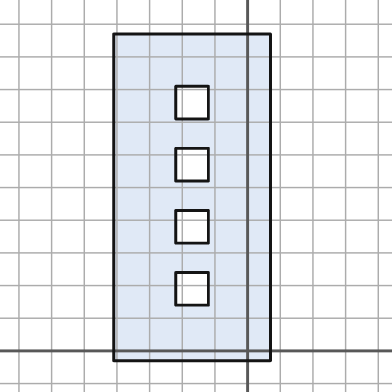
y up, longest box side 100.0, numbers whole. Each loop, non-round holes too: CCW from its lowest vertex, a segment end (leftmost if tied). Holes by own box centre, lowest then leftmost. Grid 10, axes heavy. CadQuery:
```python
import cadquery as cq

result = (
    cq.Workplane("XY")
    .moveTo(-41.0, -3.0)
    .lineTo(7.0, -3.0)
    .lineTo(7.0, 97.0)
    .lineTo(-41.0, 97.0)
    .close()
    .moveTo(-22.0, 14.0)
    .lineTo(-12.0, 14.0)
    .lineTo(-12.0, 24.0)
    .lineTo(-22.0, 24.0)
    .close()
    .moveTo(-22.0, 33.0)
    .lineTo(-12.0, 33.0)
    .lineTo(-12.0, 43.0)
    .lineTo(-22.0, 43.0)
    .close()
    .moveTo(-22.0, 52.0)
    .lineTo(-12.0, 52.0)
    .lineTo(-12.0, 62.0)
    .lineTo(-22.0, 62.0)
    .close()
    .moveTo(-22.0, 71.0)
    .lineTo(-12.0, 71.0)
    .lineTo(-12.0, 81.0)
    .lineTo(-22.0, 81.0)
    .close()
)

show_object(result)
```